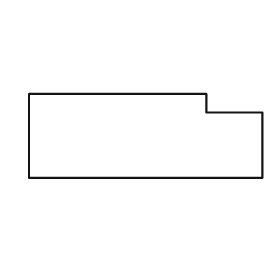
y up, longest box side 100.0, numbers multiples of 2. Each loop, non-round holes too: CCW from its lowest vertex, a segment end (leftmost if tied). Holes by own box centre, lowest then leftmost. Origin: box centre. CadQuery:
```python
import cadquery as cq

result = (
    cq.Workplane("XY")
    .moveTo(-50.0, -18.0)
    .lineTo(50.0, -18.0)
    .lineTo(50.0, 10.0)
    .lineTo(26.0, 10.0)
    .lineTo(26.0, 18.0)
    .lineTo(-50.0, 18.0)
    .close()
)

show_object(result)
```